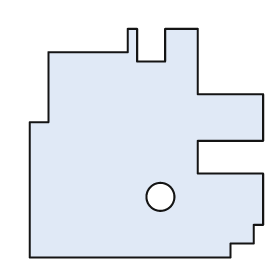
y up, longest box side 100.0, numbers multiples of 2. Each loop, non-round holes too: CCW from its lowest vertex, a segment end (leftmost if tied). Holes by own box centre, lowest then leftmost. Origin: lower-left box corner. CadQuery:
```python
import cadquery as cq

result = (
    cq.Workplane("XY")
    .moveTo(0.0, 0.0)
    .lineTo(86.0, 0.0)
    .lineTo(86.0, 6.0)
    .lineTo(96.0, 6.0)
    .lineTo(96.0, 14.0)
    .lineTo(100.0, 14.0)
    .lineTo(100.0, 36.0)
    .lineTo(72.0, 36.0)
    .lineTo(72.0, 50.0)
    .lineTo(100.0, 50.0)
    .lineTo(100.0, 70.0)
    .lineTo(72.0, 70.0)
    .lineTo(72.0, 98.0)
    .lineTo(58.0, 98.0)
    .lineTo(58.0, 84.0)
    .lineTo(46.0, 84.0)
    .lineTo(46.0, 98.0)
    .lineTo(42.0, 98.0)
    .lineTo(42.0, 88.0)
    .lineTo(8.0, 88.0)
    .lineTo(8.0, 58.0)
    .lineTo(0.0, 58.0)
    .close()
    .moveTo(56.0, 26.0)
    .circle(6.0)
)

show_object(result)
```